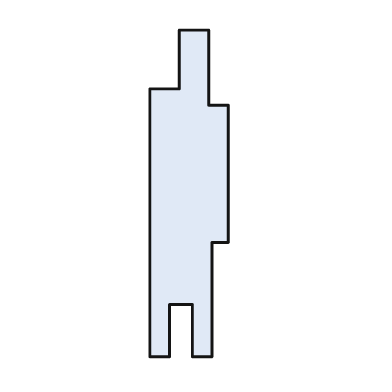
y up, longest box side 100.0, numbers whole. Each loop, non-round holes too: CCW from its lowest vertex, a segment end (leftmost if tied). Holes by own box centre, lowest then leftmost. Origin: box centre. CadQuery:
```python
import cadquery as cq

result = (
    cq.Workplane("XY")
    .moveTo(-12.0, -50.0)
    .lineTo(-6.0, -50.0)
    .lineTo(-6.0, -34.0)
    .lineTo(1.0, -34.0)
    .lineTo(1.0, -50.0)
    .lineTo(7.0, -50.0)
    .lineTo(7.0, -15.0)
    .lineTo(12.0, -15.0)
    .lineTo(12.0, 27.0)
    .lineTo(6.0, 27.0)
    .lineTo(6.0, 50.0)
    .lineTo(-3.0, 50.0)
    .lineTo(-3.0, 32.0)
    .lineTo(-12.0, 32.0)
    .close()
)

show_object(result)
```